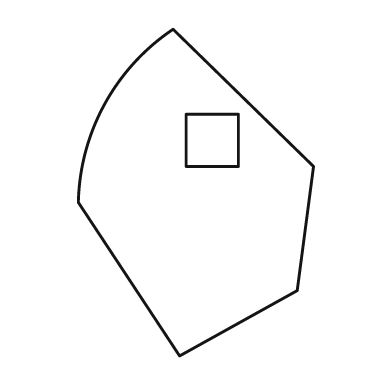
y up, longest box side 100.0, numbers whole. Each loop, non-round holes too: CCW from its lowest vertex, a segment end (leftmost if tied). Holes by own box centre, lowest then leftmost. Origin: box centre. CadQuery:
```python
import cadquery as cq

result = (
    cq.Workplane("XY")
    .moveTo(-5.0, -50.0)
    .lineTo(31.0, -30.0)
    .lineTo(36.0, 8.0)
    .lineTo(-7.0, 50.0)
    .threePointArc((-28.0, 27.0), (-36.0, -3.0))
    .close()
    .moveTo(-3.0, 8.0)
    .lineTo(13.0, 8.0)
    .lineTo(13.0, 24.0)
    .lineTo(-3.0, 24.0)
    .close()
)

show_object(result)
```